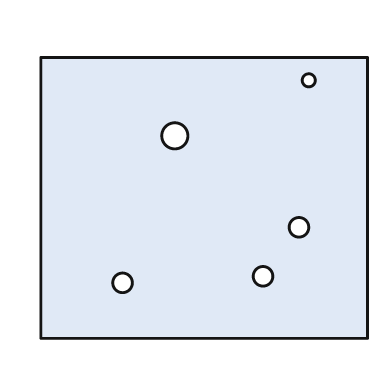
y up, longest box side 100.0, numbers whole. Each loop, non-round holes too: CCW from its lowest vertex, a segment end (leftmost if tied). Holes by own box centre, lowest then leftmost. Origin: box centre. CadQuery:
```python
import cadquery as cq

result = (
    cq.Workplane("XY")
    .moveTo(-50.0, -43.0)
    .lineTo(50.0, -43.0)
    .lineTo(50.0, 43.0)
    .lineTo(-50.0, 43.0)
    .close()
    .moveTo(-25.0, -26.0)
    .circle(3.0)
    .moveTo(18.0, -24.0)
    .circle(3.0)
    .moveTo(29.0, -9.0)
    .circle(3.0)
    .moveTo(-9.0, 19.0)
    .circle(4.0)
    .moveTo(32.0, 36.0)
    .circle(2.0)
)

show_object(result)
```